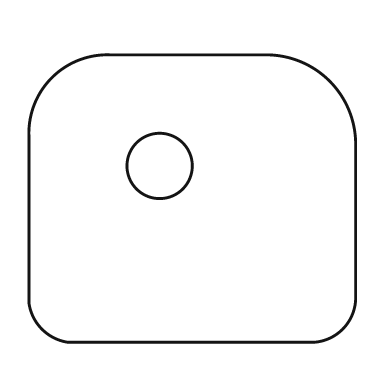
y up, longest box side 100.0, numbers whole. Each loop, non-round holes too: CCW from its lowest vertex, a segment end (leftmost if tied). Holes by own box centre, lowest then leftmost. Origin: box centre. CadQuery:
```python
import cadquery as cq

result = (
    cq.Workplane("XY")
    .moveTo(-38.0, -44.0)
    .lineTo(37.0, -44.0)
    .threePointArc((46.0, -40.0), (50.0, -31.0))
    .lineTo(50.0, 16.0)
    .threePointArc((42.0, 36.0), (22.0, 44.0))
    .lineTo(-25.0, 44.0)
    .threePointArc((-43.0, 37.0), (-50.0, 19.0))
    .lineTo(-50.0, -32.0)
    .threePointArc((-46.0, -40.0), (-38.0, -44.0))
    .close()
    .moveTo(-10.0, 10.0)
    .circle(10.0)
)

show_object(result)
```